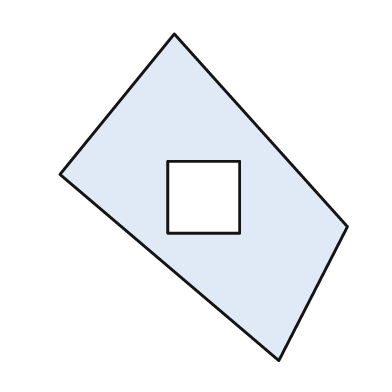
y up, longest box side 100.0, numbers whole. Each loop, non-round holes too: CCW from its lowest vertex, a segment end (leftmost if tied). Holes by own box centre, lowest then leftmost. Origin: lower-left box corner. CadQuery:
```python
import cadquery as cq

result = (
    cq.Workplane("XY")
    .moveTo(67.0, 0.0)
    .lineTo(88.0, 41.0)
    .lineTo(35.0, 100.0)
    .lineTo(0.0, 57.0)
    .close()
    .moveTo(33.0, 39.0)
    .lineTo(55.0, 39.0)
    .lineTo(55.0, 61.0)
    .lineTo(33.0, 61.0)
    .close()
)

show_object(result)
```